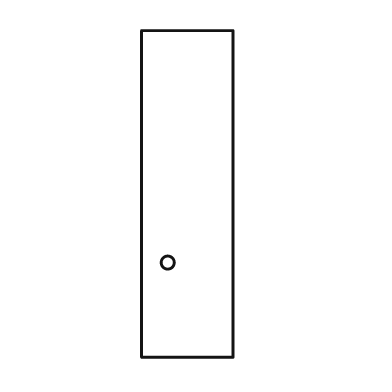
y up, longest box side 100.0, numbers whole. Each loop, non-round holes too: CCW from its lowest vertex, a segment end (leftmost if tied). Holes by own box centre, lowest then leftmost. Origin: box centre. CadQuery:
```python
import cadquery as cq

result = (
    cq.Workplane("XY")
    .moveTo(-14.0, -50.0)
    .lineTo(14.0, -50.0)
    .lineTo(14.0, 50.0)
    .lineTo(-14.0, 50.0)
    .close()
    .moveTo(-6.0, -21.0)
    .circle(2.0)
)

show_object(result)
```